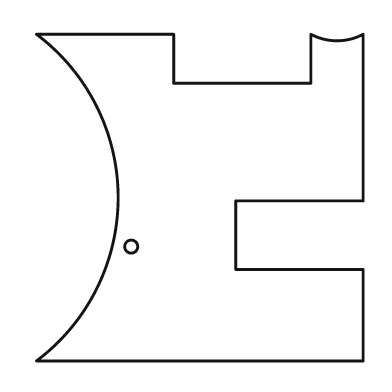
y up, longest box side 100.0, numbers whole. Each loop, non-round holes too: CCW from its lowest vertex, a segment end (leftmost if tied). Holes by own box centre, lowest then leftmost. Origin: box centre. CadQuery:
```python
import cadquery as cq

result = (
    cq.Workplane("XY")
    .moveTo(-50.0, -50.0)
    .lineTo(50.0, -50.0)
    .lineTo(50.0, -22.0)
    .lineTo(11.0, -22.0)
    .lineTo(11.0, -1.0)
    .lineTo(50.0, -1.0)
    .lineTo(50.0, 50.0)
    .threePointArc((42.0, 48.0), (34.0, 50.0))
    .lineTo(34.0, 35.0)
    .lineTo(-8.0, 35.0)
    .lineTo(-8.0, 50.0)
    .lineTo(-50.0, 50.0)
    .threePointArc((-25.0, 0.0), (-50.0, -50.0))
    .close()
    .moveTo(-21.0, -15.0)
    .circle(2.0)
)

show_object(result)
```